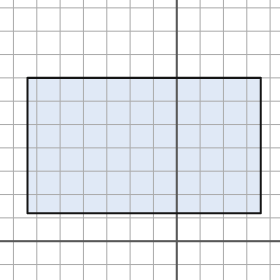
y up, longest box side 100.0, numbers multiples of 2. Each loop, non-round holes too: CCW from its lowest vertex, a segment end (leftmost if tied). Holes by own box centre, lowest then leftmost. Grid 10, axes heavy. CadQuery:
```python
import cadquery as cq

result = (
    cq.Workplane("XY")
    .moveTo(-64.0, 12.0)
    .lineTo(36.0, 12.0)
    .lineTo(36.0, 70.0)
    .lineTo(-64.0, 70.0)
    .close()
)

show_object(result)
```